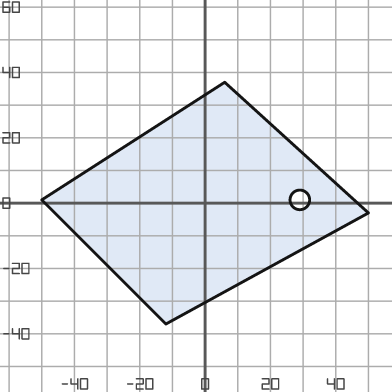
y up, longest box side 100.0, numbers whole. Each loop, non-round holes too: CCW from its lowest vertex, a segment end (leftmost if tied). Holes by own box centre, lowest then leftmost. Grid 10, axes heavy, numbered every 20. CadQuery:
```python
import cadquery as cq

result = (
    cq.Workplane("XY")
    .moveTo(-12.0, -37.0)
    .lineTo(50.0, -3.0)
    .lineTo(6.0, 37.0)
    .lineTo(-50.0, 1.0)
    .close()
    .moveTo(29.0, 1.0)
    .circle(3.0)
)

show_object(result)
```